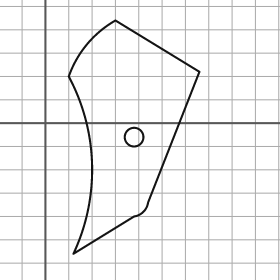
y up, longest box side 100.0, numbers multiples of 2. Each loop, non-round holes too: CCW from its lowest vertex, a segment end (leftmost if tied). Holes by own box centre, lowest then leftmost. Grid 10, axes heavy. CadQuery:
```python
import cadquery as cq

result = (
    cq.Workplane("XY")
    .moveTo(12.0, -56.0)
    .lineTo(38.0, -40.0)
    .threePointArc((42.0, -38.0), (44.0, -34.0))
    .lineTo(66.0, 22.0)
    .lineTo(30.0, 44.0)
    .threePointArc((18.0, 34.0), (10.0, 20.0))
    .threePointArc((20.0, -18.0), (12.0, -56.0))
    .close()
    .moveTo(38.0, -6.0)
    .circle(4.0)
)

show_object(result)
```